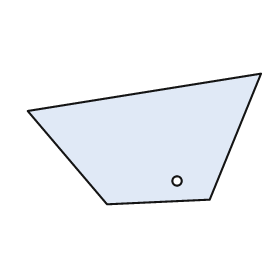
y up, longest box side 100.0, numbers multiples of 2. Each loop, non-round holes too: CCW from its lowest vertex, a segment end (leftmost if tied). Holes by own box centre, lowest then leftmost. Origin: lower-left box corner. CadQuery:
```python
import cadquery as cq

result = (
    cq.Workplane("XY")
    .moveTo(34.0, 0.0)
    .lineTo(78.0, 2.0)
    .lineTo(100.0, 56.0)
    .lineTo(0.0, 40.0)
    .close()
    .moveTo(64.0, 10.0)
    .circle(2.0)
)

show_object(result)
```